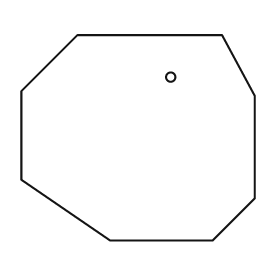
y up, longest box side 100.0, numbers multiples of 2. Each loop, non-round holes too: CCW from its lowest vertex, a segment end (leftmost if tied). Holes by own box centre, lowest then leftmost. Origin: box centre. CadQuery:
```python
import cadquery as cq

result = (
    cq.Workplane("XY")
    .moveTo(-12.0, -44.0)
    .lineTo(32.0, -44.0)
    .lineTo(50.0, -26.0)
    .lineTo(50.0, 18.0)
    .lineTo(36.0, 44.0)
    .lineTo(-26.0, 44.0)
    .lineTo(-50.0, 20.0)
    .lineTo(-50.0, -18.0)
    .close()
    .moveTo(14.0, 26.0)
    .circle(2.0)
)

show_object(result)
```